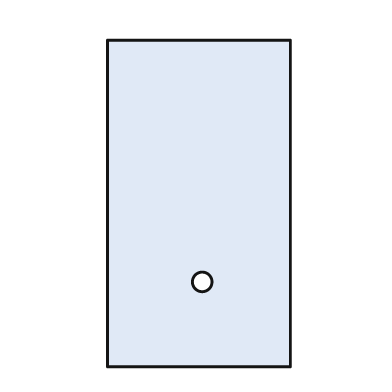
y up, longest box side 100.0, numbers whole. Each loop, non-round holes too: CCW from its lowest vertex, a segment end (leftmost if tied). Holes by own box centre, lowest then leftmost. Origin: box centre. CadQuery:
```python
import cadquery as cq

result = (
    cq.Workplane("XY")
    .moveTo(-28.0, -50.0)
    .lineTo(28.0, -50.0)
    .lineTo(28.0, 50.0)
    .lineTo(-28.0, 50.0)
    .close()
    .moveTo(1.0, -24.0)
    .circle(3.0)
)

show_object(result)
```